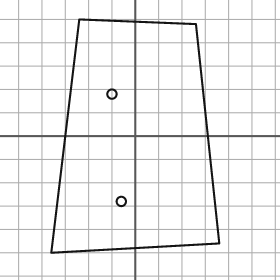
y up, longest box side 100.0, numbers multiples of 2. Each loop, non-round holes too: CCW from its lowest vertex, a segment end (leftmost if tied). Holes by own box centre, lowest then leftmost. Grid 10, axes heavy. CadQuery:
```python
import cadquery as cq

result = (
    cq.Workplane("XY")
    .moveTo(-36.0, -50.0)
    .lineTo(36.0, -46.0)
    .lineTo(26.0, 48.0)
    .lineTo(-24.0, 50.0)
    .close()
    .moveTo(-6.0, -28.0)
    .circle(2.0)
    .moveTo(-10.0, 18.0)
    .circle(2.0)
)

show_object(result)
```